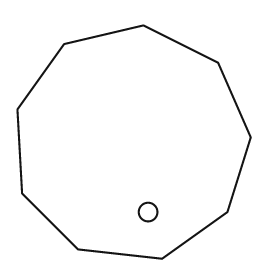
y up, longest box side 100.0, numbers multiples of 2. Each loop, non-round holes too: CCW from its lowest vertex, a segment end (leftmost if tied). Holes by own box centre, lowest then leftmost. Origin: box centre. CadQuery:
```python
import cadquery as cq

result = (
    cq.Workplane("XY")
    .moveTo(12.0, -50.0)
    .lineTo(40.0, -30.0)
    .lineTo(50.0, 2.0)
    .lineTo(36.0, 34.0)
    .lineTo(4.0, 50.0)
    .lineTo(-30.0, 42.0)
    .lineTo(-50.0, 14.0)
    .lineTo(-48.0, -22.0)
    .lineTo(-24.0, -46.0)
    .close()
    .moveTo(6.0, -30.0)
    .circle(4.0)
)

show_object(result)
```